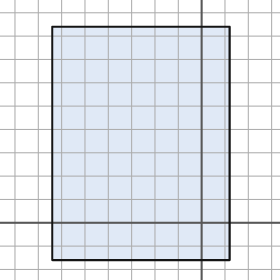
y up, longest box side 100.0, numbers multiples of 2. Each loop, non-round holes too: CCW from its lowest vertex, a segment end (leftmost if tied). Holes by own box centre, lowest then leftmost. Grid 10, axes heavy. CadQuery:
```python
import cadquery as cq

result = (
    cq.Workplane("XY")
    .moveTo(-64.0, -16.0)
    .lineTo(12.0, -16.0)
    .lineTo(12.0, 84.0)
    .lineTo(-64.0, 84.0)
    .close()
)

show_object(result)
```